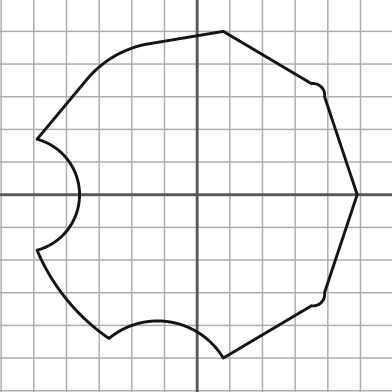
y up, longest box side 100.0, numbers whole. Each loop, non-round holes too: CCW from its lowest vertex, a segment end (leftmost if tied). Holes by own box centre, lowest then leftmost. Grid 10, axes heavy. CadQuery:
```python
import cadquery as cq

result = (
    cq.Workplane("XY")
    .moveTo(8.0, -50.0)
    .lineTo(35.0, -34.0)
    .threePointArc((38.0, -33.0), (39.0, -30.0))
    .lineTo(49.0, 0.0)
    .lineTo(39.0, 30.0)
    .threePointArc((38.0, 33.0), (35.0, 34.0))
    .lineTo(8.0, 50.0)
    .lineTo(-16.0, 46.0)
    .threePointArc((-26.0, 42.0), (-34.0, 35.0))
    .lineTo(-49.0, 17.0)
    .threePointArc((-36.0, 0.0), (-49.0, -17.0))
    .threePointArc((-40.0, -32.0), (-27.0, -44.0))
    .threePointArc((-8.0, -39.0), (8.0, -50.0))
    .close()
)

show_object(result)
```